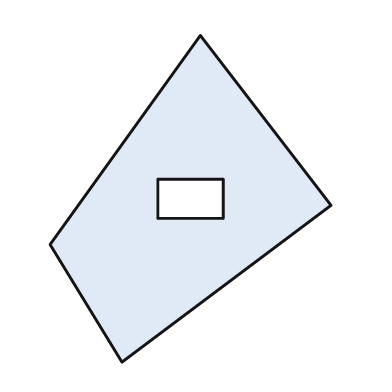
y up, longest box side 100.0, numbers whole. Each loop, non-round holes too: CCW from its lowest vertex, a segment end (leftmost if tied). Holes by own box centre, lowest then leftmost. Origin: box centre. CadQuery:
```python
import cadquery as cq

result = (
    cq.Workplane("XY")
    .moveTo(-21.0, -50.0)
    .lineTo(43.0, -2.0)
    .lineTo(3.0, 50.0)
    .lineTo(-43.0, -14.0)
    .close()
    .moveTo(-10.0, -6.0)
    .lineTo(10.0, -6.0)
    .lineTo(10.0, 6.0)
    .lineTo(-10.0, 6.0)
    .close()
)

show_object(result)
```